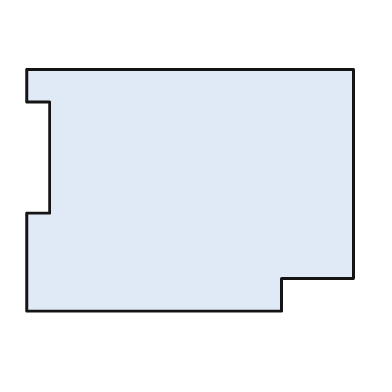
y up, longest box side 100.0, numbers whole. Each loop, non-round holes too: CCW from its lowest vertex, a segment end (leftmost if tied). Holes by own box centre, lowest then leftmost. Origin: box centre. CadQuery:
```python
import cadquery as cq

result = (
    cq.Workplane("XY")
    .moveTo(-50.0, -37.0)
    .lineTo(28.0, -37.0)
    .lineTo(28.0, -27.0)
    .lineTo(50.0, -27.0)
    .lineTo(50.0, 37.0)
    .lineTo(-50.0, 37.0)
    .lineTo(-50.0, 27.0)
    .lineTo(-43.0, 27.0)
    .lineTo(-43.0, -7.0)
    .lineTo(-50.0, -7.0)
    .close()
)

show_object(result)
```